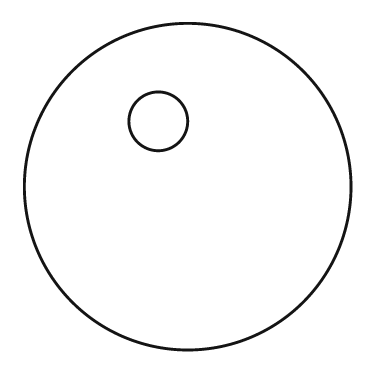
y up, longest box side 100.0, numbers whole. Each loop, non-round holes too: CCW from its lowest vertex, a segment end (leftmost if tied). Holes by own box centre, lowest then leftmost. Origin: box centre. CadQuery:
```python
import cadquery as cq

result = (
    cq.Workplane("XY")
    .moveTo(0.0, 0.0)
    .circle(50.0)
    .moveTo(-9.0, 20.0)
    .circle(9.0)
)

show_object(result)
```